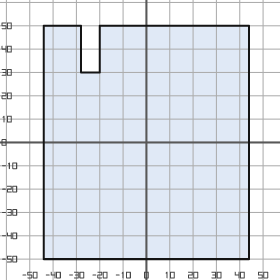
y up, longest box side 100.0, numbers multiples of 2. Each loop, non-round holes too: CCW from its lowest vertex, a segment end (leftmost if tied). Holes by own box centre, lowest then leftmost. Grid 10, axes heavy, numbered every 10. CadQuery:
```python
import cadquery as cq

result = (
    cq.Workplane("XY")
    .moveTo(-44.0, -50.0)
    .lineTo(44.0, -50.0)
    .lineTo(44.0, 50.0)
    .lineTo(-20.0, 50.0)
    .lineTo(-20.0, 30.0)
    .lineTo(-28.0, 30.0)
    .lineTo(-28.0, 50.0)
    .lineTo(-44.0, 50.0)
    .close()
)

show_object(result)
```